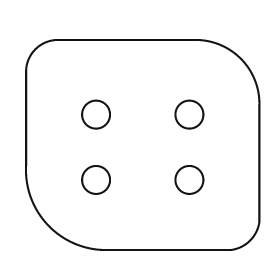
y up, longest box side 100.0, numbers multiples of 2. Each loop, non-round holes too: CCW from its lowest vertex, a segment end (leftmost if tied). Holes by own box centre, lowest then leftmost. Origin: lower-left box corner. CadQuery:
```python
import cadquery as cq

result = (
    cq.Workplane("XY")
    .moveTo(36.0, 0.0)
    .lineTo(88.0, 0.0)
    .threePointArc((96.0, 4.0), (100.0, 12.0))
    .lineTo(100.0, 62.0)
    .threePointArc((92.0, 82.0), (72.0, 90.0))
    .lineTo(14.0, 90.0)
    .threePointArc((4.0, 86.0), (0.0, 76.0))
    .lineTo(0.0, 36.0)
    .threePointArc((10.0, 10.0), (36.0, 0.0))
    .close()
    .moveTo(30.0, 30.0)
    .circle(6.0)
    .moveTo(70.0, 30.0)
    .circle(6.0)
    .moveTo(30.0, 58.0)
    .circle(6.0)
    .moveTo(70.0, 58.0)
    .circle(6.0)
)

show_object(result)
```